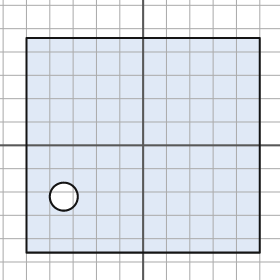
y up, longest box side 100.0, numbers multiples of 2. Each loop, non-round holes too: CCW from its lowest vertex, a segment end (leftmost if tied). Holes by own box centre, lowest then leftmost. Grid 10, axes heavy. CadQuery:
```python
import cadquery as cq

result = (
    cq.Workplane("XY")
    .moveTo(-50.0, -46.0)
    .lineTo(50.0, -46.0)
    .lineTo(50.0, 46.0)
    .lineTo(-50.0, 46.0)
    .close()
    .moveTo(-34.0, -22.0)
    .circle(6.0)
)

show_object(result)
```